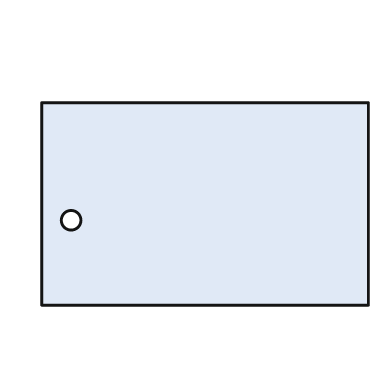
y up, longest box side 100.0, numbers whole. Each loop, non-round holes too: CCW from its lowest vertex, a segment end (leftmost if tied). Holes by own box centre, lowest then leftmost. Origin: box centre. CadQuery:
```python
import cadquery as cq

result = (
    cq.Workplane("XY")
    .moveTo(-50.0, -31.0)
    .lineTo(50.0, -31.0)
    .lineTo(50.0, 31.0)
    .lineTo(-50.0, 31.0)
    .close()
    .moveTo(-41.0, -5.0)
    .circle(3.0)
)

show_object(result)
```